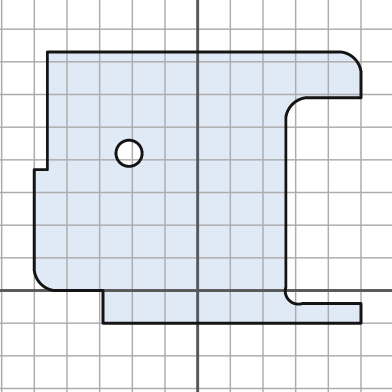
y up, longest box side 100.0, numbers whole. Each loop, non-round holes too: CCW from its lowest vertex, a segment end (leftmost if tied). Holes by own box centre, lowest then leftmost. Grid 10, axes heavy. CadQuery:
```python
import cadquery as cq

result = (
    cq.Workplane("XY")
    .moveTo(-29.0, -10.0)
    .lineTo(50.0, -10.0)
    .lineTo(50.0, -4.0)
    .lineTo(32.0, -4.0)
    .threePointArc((28.0, -3.0), (27.0, 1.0))
    .lineTo(27.0, 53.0)
    .threePointArc((29.0, 57.0), (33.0, 59.0))
    .lineTo(50.0, 59.0)
    .lineTo(50.0, 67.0)
    .threePointArc((48.0, 71.0), (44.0, 73.0))
    .lineTo(-46.0, 73.0)
    .lineTo(-46.0, 37.0)
    .lineTo(-50.0, 37.0)
    .lineTo(-50.0, 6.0)
    .threePointArc((-48.0, 2.0), (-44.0, 0.0))
    .lineTo(-29.0, 0.0)
    .close()
    .moveTo(-21.0, 42.0)
    .circle(4.0)
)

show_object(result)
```